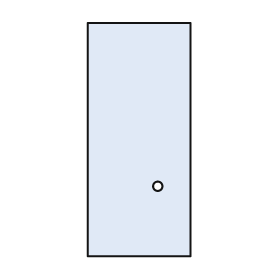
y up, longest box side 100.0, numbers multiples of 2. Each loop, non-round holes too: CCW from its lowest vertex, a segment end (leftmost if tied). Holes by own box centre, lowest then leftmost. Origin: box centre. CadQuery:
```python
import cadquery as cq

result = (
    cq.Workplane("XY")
    .moveTo(-22.0, -50.0)
    .lineTo(22.0, -50.0)
    .lineTo(22.0, 50.0)
    .lineTo(-22.0, 50.0)
    .close()
    .moveTo(8.0, -20.0)
    .circle(2.0)
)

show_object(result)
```